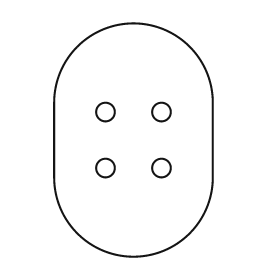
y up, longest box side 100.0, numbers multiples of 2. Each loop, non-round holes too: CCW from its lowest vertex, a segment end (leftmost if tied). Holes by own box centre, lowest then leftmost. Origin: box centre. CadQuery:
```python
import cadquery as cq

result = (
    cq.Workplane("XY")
    .moveTo(-34.0, -16.0)
    .threePointArc((0.0, -50.0), (34.0, -16.0))
    .lineTo(34.0, 16.0)
    .threePointArc((0.0, 50.0), (-34.0, 16.0))
    .close()
    .moveTo(-12.0, -12.0)
    .circle(4.0)
    .moveTo(12.0, -12.0)
    .circle(4.0)
    .moveTo(-12.0, 12.0)
    .circle(4.0)
    .moveTo(12.0, 12.0)
    .circle(4.0)
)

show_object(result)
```